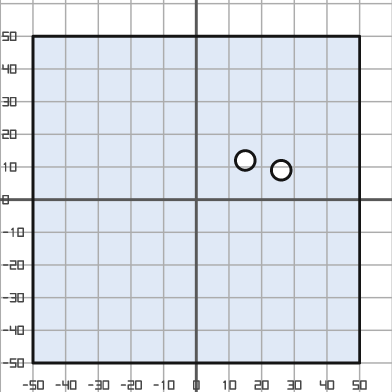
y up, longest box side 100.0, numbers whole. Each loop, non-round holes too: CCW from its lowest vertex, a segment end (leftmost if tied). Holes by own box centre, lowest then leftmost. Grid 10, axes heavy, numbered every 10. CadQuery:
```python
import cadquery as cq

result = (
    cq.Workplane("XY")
    .moveTo(-50.0, -50.0)
    .lineTo(50.0, -50.0)
    .lineTo(50.0, 50.0)
    .lineTo(-50.0, 50.0)
    .close()
    .moveTo(26.0, 9.0)
    .circle(3.0)
    .moveTo(15.0, 12.0)
    .circle(3.0)
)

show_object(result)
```